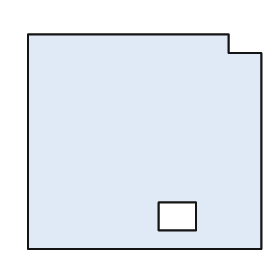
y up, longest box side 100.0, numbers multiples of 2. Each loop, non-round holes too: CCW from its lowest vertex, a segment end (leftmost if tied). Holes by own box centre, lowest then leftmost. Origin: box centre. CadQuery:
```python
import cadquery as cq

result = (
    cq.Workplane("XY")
    .moveTo(-50.0, -46.0)
    .lineTo(50.0, -46.0)
    .lineTo(50.0, 38.0)
    .lineTo(36.0, 38.0)
    .lineTo(36.0, 46.0)
    .lineTo(-50.0, 46.0)
    .close()
    .moveTo(6.0, -38.0)
    .lineTo(22.0, -38.0)
    .lineTo(22.0, -26.0)
    .lineTo(6.0, -26.0)
    .close()
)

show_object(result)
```